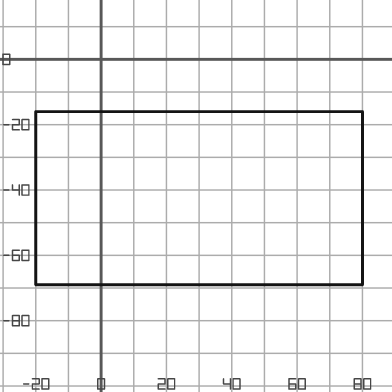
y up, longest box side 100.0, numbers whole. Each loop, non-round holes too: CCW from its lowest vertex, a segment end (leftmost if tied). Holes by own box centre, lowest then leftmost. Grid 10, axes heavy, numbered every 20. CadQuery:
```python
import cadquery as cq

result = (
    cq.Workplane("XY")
    .moveTo(-20.0, -69.0)
    .lineTo(80.0, -69.0)
    .lineTo(80.0, -16.0)
    .lineTo(-20.0, -16.0)
    .close()
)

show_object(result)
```